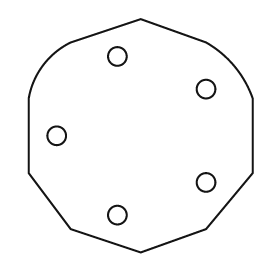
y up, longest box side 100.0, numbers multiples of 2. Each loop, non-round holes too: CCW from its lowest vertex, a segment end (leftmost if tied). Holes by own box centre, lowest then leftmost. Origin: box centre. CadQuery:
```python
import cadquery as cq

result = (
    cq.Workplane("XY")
    .moveTo(0.0, -50.0)
    .lineTo(28.0, -40.0)
    .lineTo(48.0, -16.0)
    .lineTo(48.0, 16.0)
    .threePointArc((40.0, 30.0), (28.0, 40.0))
    .lineTo(0.0, 50.0)
    .lineTo(-30.0, 40.0)
    .threePointArc((-42.0, 30.0), (-48.0, 16.0))
    .lineTo(-48.0, -16.0)
    .lineTo(-30.0, -40.0)
    .close()
    .moveTo(-10.0, -34.0)
    .circle(4.0)
    .moveTo(28.0, -20.0)
    .circle(4.0)
    .moveTo(-36.0, 0.0)
    .circle(4.0)
    .moveTo(28.0, 20.0)
    .circle(4.0)
    .moveTo(-10.0, 34.0)
    .circle(4.0)
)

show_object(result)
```